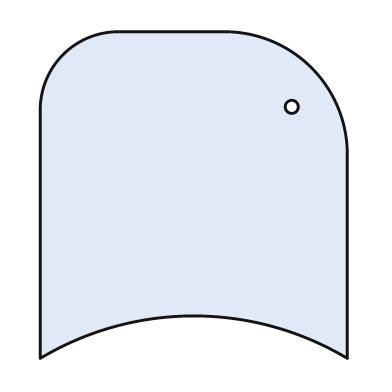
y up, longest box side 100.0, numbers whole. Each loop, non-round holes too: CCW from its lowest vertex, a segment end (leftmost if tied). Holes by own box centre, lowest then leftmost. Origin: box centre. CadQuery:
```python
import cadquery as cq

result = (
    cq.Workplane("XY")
    .moveTo(-47.0, -50.0)
    .threePointArc((0.0, -37.0), (47.0, -50.0))
    .lineTo(47.0, 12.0)
    .threePointArc((36.0, 39.0), (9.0, 50.0))
    .lineTo(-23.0, 50.0)
    .threePointArc((-40.0, 43.0), (-47.0, 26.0))
    .close()
    .moveTo(30.0, 27.0)
    .circle(2.0)
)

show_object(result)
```